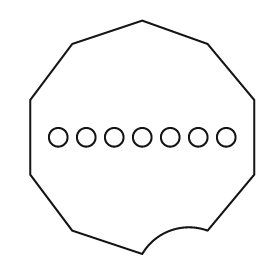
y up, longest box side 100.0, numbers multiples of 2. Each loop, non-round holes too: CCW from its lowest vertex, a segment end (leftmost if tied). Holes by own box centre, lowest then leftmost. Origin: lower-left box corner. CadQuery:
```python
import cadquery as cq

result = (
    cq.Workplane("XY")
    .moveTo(48.0, 0.0)
    .threePointArc((60.0, 10.0), (76.0, 10.0))
    .lineTo(96.0, 34.0)
    .lineTo(96.0, 66.0)
    .lineTo(76.0, 90.0)
    .lineTo(48.0, 100.0)
    .lineTo(18.0, 90.0)
    .lineTo(0.0, 66.0)
    .lineTo(0.0, 34.0)
    .lineTo(18.0, 10.0)
    .close()
    .moveTo(12.0, 50.0)
    .circle(4.0)
    .moveTo(24.0, 50.0)
    .circle(4.0)
    .moveTo(36.0, 50.0)
    .circle(4.0)
    .moveTo(48.0, 50.0)
    .circle(4.0)
    .moveTo(60.0, 50.0)
    .circle(4.0)
    .moveTo(72.0, 50.0)
    .circle(4.0)
    .moveTo(84.0, 50.0)
    .circle(4.0)
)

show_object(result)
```